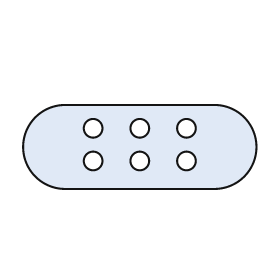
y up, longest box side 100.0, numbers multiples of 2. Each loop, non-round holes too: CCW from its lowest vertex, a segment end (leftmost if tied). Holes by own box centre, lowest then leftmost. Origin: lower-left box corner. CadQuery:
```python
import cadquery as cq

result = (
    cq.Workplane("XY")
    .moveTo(18.0, 0.0)
    .lineTo(82.0, 0.0)
    .threePointArc((100.0, 18.0), (82.0, 36.0))
    .lineTo(18.0, 36.0)
    .threePointArc((0.0, 18.0), (18.0, 0.0))
    .close()
    .moveTo(30.0, 12.0)
    .circle(4.0)
    .moveTo(50.0, 12.0)
    .circle(4.0)
    .moveTo(70.0, 12.0)
    .circle(4.0)
    .moveTo(30.0, 26.0)
    .circle(4.0)
    .moveTo(50.0, 26.0)
    .circle(4.0)
    .moveTo(70.0, 26.0)
    .circle(4.0)
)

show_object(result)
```